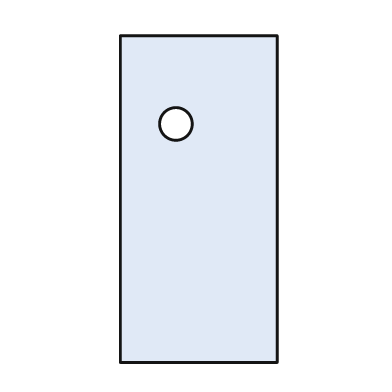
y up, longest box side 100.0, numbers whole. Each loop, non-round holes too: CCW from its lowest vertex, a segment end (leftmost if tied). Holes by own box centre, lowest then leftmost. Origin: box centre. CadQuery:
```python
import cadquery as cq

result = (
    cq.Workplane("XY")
    .moveTo(-24.0, -50.0)
    .lineTo(24.0, -50.0)
    .lineTo(24.0, 50.0)
    .lineTo(-24.0, 50.0)
    .close()
    .moveTo(-7.0, 23.0)
    .circle(5.0)
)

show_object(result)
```